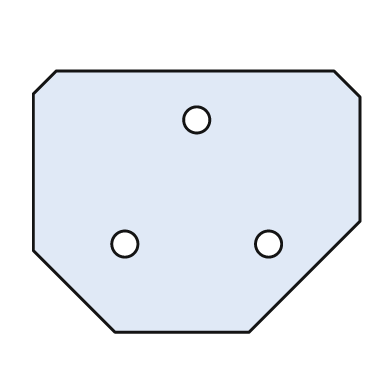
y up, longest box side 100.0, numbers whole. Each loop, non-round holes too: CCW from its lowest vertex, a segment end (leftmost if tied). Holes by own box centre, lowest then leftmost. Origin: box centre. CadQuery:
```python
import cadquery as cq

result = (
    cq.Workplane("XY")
    .moveTo(-25.0, -40.0)
    .lineTo(16.0, -40.0)
    .lineTo(50.0, -6.0)
    .lineTo(50.0, 32.0)
    .lineTo(42.0, 40.0)
    .lineTo(-43.0, 40.0)
    .lineTo(-50.0, 33.0)
    .lineTo(-50.0, -15.0)
    .close()
    .moveTo(-22.0, -13.0)
    .circle(4.0)
    .moveTo(22.0, -13.0)
    .circle(4.0)
    .moveTo(0.0, 25.0)
    .circle(4.0)
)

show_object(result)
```